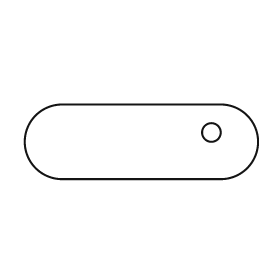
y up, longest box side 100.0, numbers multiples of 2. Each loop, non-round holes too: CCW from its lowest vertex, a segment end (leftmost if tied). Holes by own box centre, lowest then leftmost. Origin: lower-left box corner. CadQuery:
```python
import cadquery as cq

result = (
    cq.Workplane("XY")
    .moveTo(16.0, 0.0)
    .lineTo(84.0, 0.0)
    .threePointArc((100.0, 16.0), (84.0, 32.0))
    .lineTo(16.0, 32.0)
    .threePointArc((0.0, 16.0), (16.0, 0.0))
    .close()
    .moveTo(80.0, 20.0)
    .circle(4.0)
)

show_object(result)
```